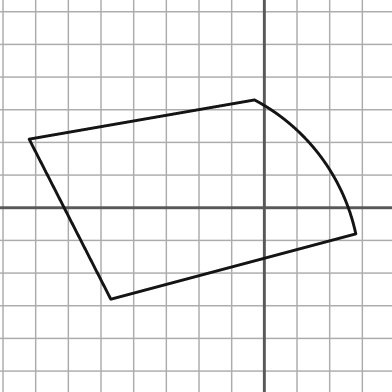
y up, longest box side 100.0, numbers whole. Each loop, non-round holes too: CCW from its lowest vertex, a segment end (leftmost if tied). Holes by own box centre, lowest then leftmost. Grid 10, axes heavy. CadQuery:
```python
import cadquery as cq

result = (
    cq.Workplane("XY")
    .moveTo(-47.0, -28.0)
    .lineTo(28.0, -8.0)
    .threePointArc((17.0, 16.0), (-3.0, 33.0))
    .lineTo(-72.0, 21.0)
    .close()
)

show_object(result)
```